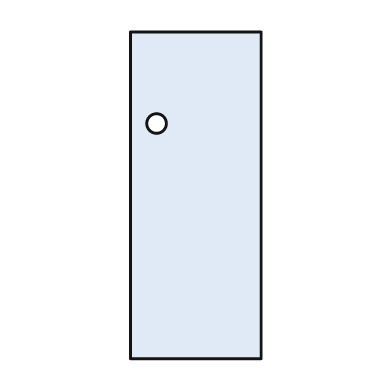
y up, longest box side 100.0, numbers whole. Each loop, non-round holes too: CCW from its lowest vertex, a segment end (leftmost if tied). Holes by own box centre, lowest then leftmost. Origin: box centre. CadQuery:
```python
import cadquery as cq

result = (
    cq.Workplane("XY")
    .moveTo(-20.0, -50.0)
    .lineTo(20.0, -50.0)
    .lineTo(20.0, 50.0)
    .lineTo(-20.0, 50.0)
    .close()
    .moveTo(-12.0, 22.0)
    .circle(3.0)
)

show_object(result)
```